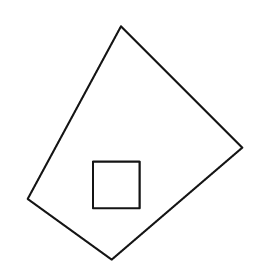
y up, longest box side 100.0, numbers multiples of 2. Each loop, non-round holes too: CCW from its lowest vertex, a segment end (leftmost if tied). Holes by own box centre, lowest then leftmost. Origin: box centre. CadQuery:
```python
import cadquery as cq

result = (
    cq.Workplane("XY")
    .moveTo(-10.0, -50.0)
    .lineTo(46.0, -2.0)
    .lineTo(-6.0, 50.0)
    .lineTo(-46.0, -24.0)
    .close()
    .moveTo(-18.0, -28.0)
    .lineTo(2.0, -28.0)
    .lineTo(2.0, -8.0)
    .lineTo(-18.0, -8.0)
    .close()
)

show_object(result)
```